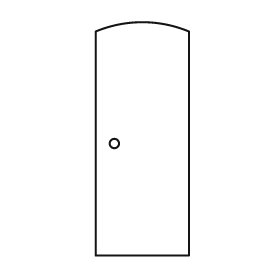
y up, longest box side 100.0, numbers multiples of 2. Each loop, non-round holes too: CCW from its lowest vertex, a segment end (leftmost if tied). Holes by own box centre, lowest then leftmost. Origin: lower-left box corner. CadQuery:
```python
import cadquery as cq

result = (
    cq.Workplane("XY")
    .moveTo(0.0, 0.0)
    .lineTo(40.0, 0.0)
    .lineTo(40.0, 96.0)
    .threePointArc((20.0, 100.0), (0.0, 96.0))
    .close()
    .moveTo(8.0, 48.0)
    .circle(2.0)
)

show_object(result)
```